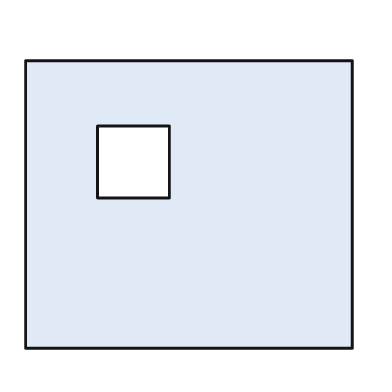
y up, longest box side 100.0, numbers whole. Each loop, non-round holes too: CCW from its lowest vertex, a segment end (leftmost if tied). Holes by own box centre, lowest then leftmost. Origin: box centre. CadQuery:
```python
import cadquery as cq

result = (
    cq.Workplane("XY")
    .moveTo(-50.0, -44.0)
    .lineTo(50.0, -44.0)
    .lineTo(50.0, 44.0)
    .lineTo(-50.0, 44.0)
    .close()
    .moveTo(-28.0, 2.0)
    .lineTo(-6.0, 2.0)
    .lineTo(-6.0, 24.0)
    .lineTo(-28.0, 24.0)
    .close()
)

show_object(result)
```